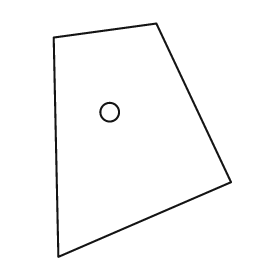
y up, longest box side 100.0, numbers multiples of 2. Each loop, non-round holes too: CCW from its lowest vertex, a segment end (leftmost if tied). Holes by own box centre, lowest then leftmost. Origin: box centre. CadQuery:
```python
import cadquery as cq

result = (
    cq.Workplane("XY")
    .moveTo(-36.0, -50.0)
    .lineTo(38.0, -18.0)
    .lineTo(6.0, 50.0)
    .lineTo(-38.0, 44.0)
    .close()
    .moveTo(-14.0, 12.0)
    .circle(4.0)
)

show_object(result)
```